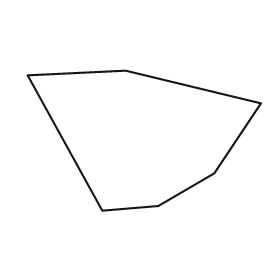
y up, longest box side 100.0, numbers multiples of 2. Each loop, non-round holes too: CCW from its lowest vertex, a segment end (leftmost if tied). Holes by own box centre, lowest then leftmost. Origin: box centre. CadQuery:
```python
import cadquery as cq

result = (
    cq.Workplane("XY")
    .moveTo(-18.0, -30.0)
    .lineTo(6.0, -28.0)
    .lineTo(30.0, -14.0)
    .lineTo(50.0, 16.0)
    .lineTo(-8.0, 30.0)
    .lineTo(-50.0, 28.0)
    .close()
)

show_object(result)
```